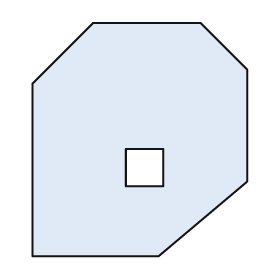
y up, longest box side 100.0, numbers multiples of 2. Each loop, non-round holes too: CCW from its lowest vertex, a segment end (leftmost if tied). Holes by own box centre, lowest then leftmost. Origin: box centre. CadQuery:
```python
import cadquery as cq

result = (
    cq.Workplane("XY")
    .moveTo(-46.0, -50.0)
    .lineTo(8.0, -50.0)
    .lineTo(46.0, -18.0)
    .lineTo(46.0, 30.0)
    .lineTo(26.0, 50.0)
    .lineTo(-20.0, 50.0)
    .lineTo(-46.0, 24.0)
    .close()
    .moveTo(-6.0, -20.0)
    .lineTo(10.0, -20.0)
    .lineTo(10.0, -4.0)
    .lineTo(-6.0, -4.0)
    .close()
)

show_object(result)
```